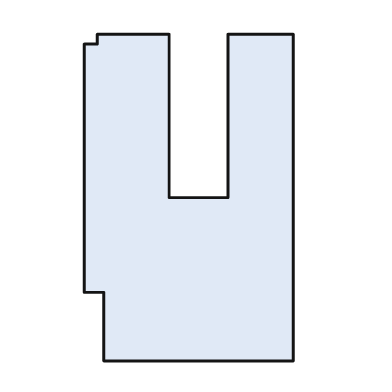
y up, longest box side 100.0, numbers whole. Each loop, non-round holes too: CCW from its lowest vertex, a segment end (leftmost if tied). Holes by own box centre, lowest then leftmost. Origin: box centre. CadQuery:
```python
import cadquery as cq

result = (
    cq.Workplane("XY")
    .moveTo(-26.0, -50.0)
    .lineTo(32.0, -50.0)
    .lineTo(32.0, 50.0)
    .lineTo(12.0, 50.0)
    .lineTo(12.0, 0.0)
    .lineTo(-6.0, 0.0)
    .lineTo(-6.0, 50.0)
    .lineTo(-28.0, 50.0)
    .lineTo(-28.0, 47.0)
    .lineTo(-32.0, 47.0)
    .lineTo(-32.0, -29.0)
    .lineTo(-26.0, -29.0)
    .close()
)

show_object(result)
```